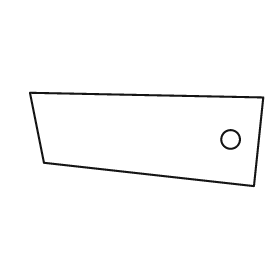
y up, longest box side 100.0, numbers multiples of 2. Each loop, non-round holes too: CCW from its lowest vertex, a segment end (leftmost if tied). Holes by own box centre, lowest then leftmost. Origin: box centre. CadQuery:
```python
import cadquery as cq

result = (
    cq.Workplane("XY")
    .moveTo(46.0, -20.0)
    .lineTo(50.0, 18.0)
    .lineTo(-50.0, 20.0)
    .lineTo(-44.0, -10.0)
    .close()
    .moveTo(36.0, 0.0)
    .circle(4.0)
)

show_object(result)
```